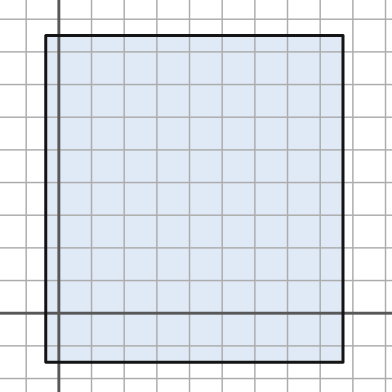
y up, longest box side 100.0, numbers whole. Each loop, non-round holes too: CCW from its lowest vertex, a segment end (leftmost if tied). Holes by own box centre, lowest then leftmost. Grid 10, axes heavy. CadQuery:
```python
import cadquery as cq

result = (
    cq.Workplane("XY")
    .moveTo(-4.0, -15.0)
    .lineTo(87.0, -15.0)
    .lineTo(87.0, 85.0)
    .lineTo(-4.0, 85.0)
    .close()
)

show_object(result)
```